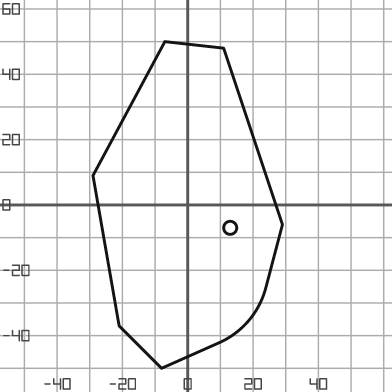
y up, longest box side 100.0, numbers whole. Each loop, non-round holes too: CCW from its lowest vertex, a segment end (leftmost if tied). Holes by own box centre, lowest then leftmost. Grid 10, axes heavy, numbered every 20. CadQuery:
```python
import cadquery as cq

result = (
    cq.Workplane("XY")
    .moveTo(-8.0, -50.0)
    .lineTo(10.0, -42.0)
    .threePointArc((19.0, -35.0), (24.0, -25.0))
    .lineTo(29.0, -6.0)
    .lineTo(11.0, 48.0)
    .lineTo(-7.0, 50.0)
    .lineTo(-29.0, 9.0)
    .lineTo(-21.0, -37.0)
    .close()
    .moveTo(13.0, -7.0)
    .circle(2.0)
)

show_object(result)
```